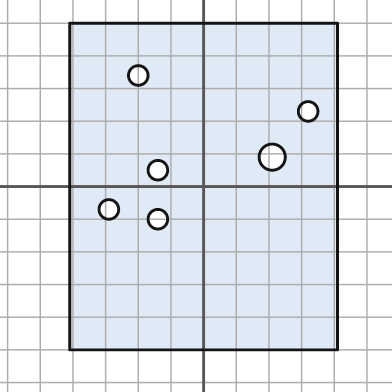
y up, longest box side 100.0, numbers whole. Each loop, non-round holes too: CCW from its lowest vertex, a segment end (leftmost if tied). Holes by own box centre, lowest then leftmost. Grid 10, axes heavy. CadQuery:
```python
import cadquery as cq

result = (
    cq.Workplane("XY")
    .moveTo(-41.0, -50.0)
    .lineTo(41.0, -50.0)
    .lineTo(41.0, 50.0)
    .lineTo(-41.0, 50.0)
    .close()
    .moveTo(-14.0, -10.0)
    .circle(3.0)
    .moveTo(-29.0, -7.0)
    .circle(3.0)
    .moveTo(-14.0, 5.0)
    .circle(3.0)
    .moveTo(21.0, 9.0)
    .circle(4.0)
    .moveTo(32.0, 23.0)
    .circle(3.0)
    .moveTo(-20.0, 34.0)
    .circle(3.0)
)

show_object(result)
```